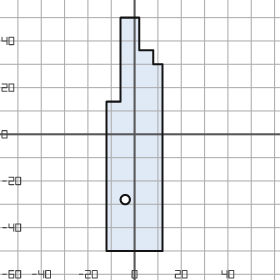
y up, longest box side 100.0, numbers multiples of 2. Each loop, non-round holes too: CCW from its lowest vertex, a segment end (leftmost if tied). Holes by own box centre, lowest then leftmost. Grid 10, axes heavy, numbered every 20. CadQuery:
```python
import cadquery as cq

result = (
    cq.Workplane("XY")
    .moveTo(-12.0, -50.0)
    .lineTo(12.0, -50.0)
    .lineTo(12.0, 30.0)
    .lineTo(8.0, 30.0)
    .lineTo(8.0, 36.0)
    .lineTo(2.0, 36.0)
    .lineTo(2.0, 50.0)
    .lineTo(-6.0, 50.0)
    .lineTo(-6.0, 14.0)
    .lineTo(-12.0, 14.0)
    .close()
    .moveTo(-4.0, -28.0)
    .circle(2.0)
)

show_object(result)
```